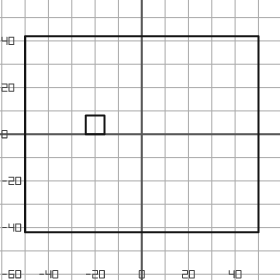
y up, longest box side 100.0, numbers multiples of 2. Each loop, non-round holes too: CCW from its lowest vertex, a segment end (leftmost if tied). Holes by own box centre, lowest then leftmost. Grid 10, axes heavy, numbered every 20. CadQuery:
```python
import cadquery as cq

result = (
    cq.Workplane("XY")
    .moveTo(-50.0, -42.0)
    .lineTo(50.0, -42.0)
    .lineTo(50.0, 42.0)
    .lineTo(-50.0, 42.0)
    .close()
    .moveTo(-24.0, 0.0)
    .lineTo(-16.0, 0.0)
    .lineTo(-16.0, 8.0)
    .lineTo(-24.0, 8.0)
    .close()
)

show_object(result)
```